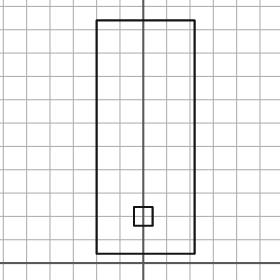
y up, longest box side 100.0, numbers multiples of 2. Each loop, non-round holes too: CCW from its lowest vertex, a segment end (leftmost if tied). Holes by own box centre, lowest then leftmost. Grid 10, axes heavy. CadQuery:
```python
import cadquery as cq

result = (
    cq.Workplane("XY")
    .moveTo(-20.0, 4.0)
    .lineTo(22.0, 4.0)
    .lineTo(22.0, 104.0)
    .lineTo(-20.0, 104.0)
    .close()
    .moveTo(-4.0, 16.0)
    .lineTo(4.0, 16.0)
    .lineTo(4.0, 24.0)
    .lineTo(-4.0, 24.0)
    .close()
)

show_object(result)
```